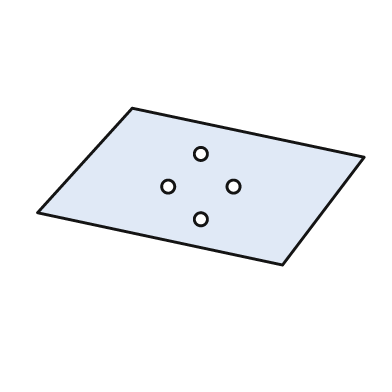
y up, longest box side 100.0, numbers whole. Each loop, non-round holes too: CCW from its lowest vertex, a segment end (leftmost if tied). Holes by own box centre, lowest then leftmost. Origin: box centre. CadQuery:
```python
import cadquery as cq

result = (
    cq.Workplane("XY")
    .moveTo(25.0, -24.0)
    .lineTo(50.0, 9.0)
    .lineTo(-21.0, 24.0)
    .lineTo(-50.0, -8.0)
    .close()
    .moveTo(0.0, -10.0)
    .circle(2.0)
    .moveTo(-10.0, 0.0)
    .circle(2.0)
    .moveTo(10.0, 0.0)
    .circle(2.0)
    .moveTo(0.0, 10.0)
    .circle(2.0)
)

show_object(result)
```